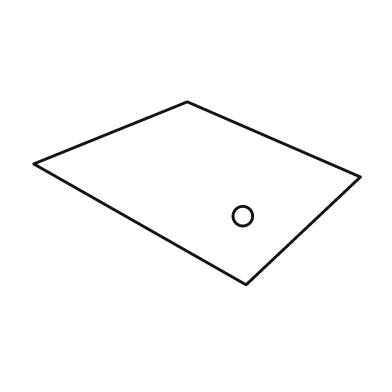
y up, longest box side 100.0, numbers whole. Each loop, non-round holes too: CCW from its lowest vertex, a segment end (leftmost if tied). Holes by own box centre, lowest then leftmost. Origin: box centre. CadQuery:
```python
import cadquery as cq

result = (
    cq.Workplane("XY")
    .moveTo(15.0, -28.0)
    .lineTo(50.0, 5.0)
    .lineTo(-3.0, 28.0)
    .lineTo(-50.0, 9.0)
    .close()
    .moveTo(14.0, -7.0)
    .circle(3.0)
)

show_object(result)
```